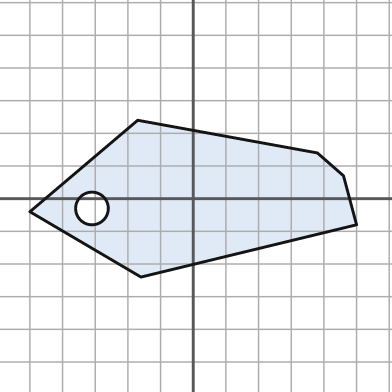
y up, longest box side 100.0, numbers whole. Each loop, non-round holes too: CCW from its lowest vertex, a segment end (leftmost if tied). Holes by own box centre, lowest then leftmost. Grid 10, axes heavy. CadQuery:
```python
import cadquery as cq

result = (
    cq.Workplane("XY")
    .moveTo(-16.0, -24.0)
    .lineTo(50.0, -8.0)
    .lineTo(46.0, 7.0)
    .lineTo(38.0, 14.0)
    .lineTo(-17.0, 24.0)
    .lineTo(-50.0, -4.0)
    .close()
    .moveTo(-31.0, -3.0)
    .circle(5.0)
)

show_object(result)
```